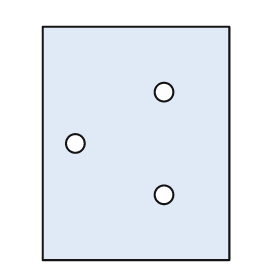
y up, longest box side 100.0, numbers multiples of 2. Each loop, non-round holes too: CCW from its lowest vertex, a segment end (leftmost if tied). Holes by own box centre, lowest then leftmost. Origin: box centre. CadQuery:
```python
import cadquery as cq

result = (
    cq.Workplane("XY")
    .moveTo(-40.0, -50.0)
    .lineTo(40.0, -50.0)
    .lineTo(40.0, 50.0)
    .lineTo(-40.0, 50.0)
    .close()
    .moveTo(12.0, -22.0)
    .circle(4.0)
    .moveTo(-26.0, 0.0)
    .circle(4.0)
    .moveTo(12.0, 22.0)
    .circle(4.0)
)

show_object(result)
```